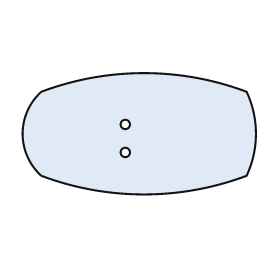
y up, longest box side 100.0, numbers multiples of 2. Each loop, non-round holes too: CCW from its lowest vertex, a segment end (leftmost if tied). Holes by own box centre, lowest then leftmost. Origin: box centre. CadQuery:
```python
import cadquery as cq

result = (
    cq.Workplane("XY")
    .moveTo(-42.0, -18.0)
    .threePointArc((2.0, -26.0), (46.0, -18.0))
    .threePointArc((50.0, 0.0), (46.0, 18.0))
    .threePointArc((2.0, 26.0), (-42.0, 18.0))
    .threePointArc((-50.0, 0.0), (-42.0, -18.0))
    .close()
    .moveTo(-6.0, -8.0)
    .circle(2.0)
    .moveTo(-6.0, 4.0)
    .circle(2.0)
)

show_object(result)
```